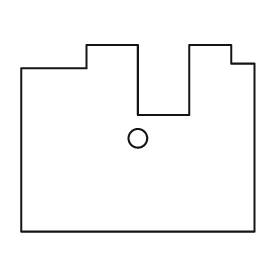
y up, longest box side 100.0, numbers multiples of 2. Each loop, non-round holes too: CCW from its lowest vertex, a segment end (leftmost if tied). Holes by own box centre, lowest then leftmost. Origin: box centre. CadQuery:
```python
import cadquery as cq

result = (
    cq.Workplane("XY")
    .moveTo(-50.0, -40.0)
    .lineTo(50.0, -40.0)
    .lineTo(50.0, 32.0)
    .lineTo(40.0, 32.0)
    .lineTo(40.0, 40.0)
    .lineTo(22.0, 40.0)
    .lineTo(22.0, 10.0)
    .lineTo(0.0, 10.0)
    .lineTo(0.0, 40.0)
    .lineTo(-22.0, 40.0)
    .lineTo(-22.0, 30.0)
    .lineTo(-50.0, 30.0)
    .close()
    .moveTo(0.0, 0.0)
    .circle(4.0)
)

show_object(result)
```